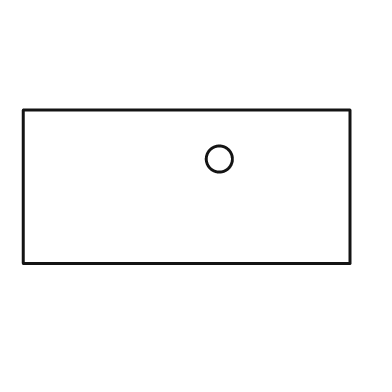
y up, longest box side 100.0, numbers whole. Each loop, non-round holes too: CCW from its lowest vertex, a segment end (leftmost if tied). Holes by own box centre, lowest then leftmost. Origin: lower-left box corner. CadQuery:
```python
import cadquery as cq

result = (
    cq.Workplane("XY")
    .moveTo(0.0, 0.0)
    .lineTo(100.0, 0.0)
    .lineTo(100.0, 47.0)
    .lineTo(0.0, 47.0)
    .close()
    .moveTo(60.0, 32.0)
    .circle(4.0)
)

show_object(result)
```